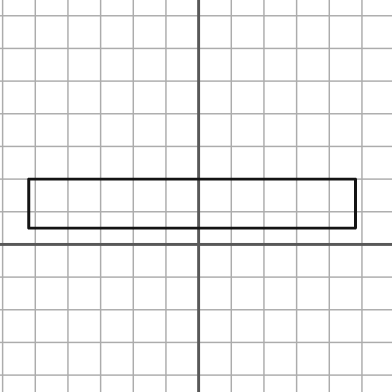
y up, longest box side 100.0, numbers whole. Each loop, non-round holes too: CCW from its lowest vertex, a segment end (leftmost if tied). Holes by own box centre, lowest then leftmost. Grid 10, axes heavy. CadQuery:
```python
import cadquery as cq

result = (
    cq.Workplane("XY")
    .moveTo(-52.0, 5.0)
    .lineTo(48.0, 5.0)
    .lineTo(48.0, 20.0)
    .lineTo(-52.0, 20.0)
    .close()
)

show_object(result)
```